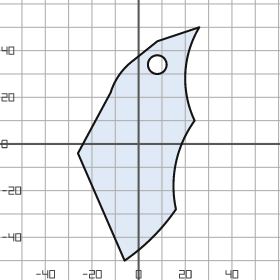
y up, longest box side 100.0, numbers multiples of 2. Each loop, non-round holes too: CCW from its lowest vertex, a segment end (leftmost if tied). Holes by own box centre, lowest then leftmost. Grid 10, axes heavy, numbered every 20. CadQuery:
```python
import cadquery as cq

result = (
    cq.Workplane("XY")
    .moveTo(-6.0, -50.0)
    .threePointArc((6.0, -40.0), (16.0, -28.0))
    .threePointArc((16.0, -8.0), (24.0, 10.0))
    .threePointArc((20.0, 30.0), (26.0, 50.0))
    .lineTo(8.0, 44.0)
    .lineTo(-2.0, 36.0)
    .threePointArc((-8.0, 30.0), (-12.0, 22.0))
    .lineTo(-26.0, -4.0)
    .close()
    .moveTo(8.0, 34.0)
    .circle(4.0)
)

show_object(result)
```